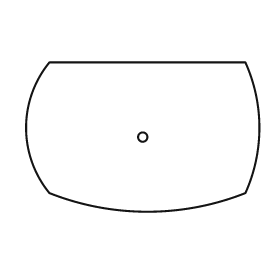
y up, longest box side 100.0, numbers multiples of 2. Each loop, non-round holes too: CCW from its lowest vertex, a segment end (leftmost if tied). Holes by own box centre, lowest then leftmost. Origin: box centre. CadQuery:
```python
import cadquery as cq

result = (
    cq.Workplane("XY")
    .moveTo(-40.0, -24.0)
    .threePointArc((2.0, -32.0), (44.0, -24.0))
    .threePointArc((50.0, 4.0), (44.0, 32.0))
    .lineTo(-40.0, 32.0)
    .threePointArc((-50.0, 4.0), (-40.0, -24.0))
    .close()
    .moveTo(0.0, 0.0)
    .circle(2.0)
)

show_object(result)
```